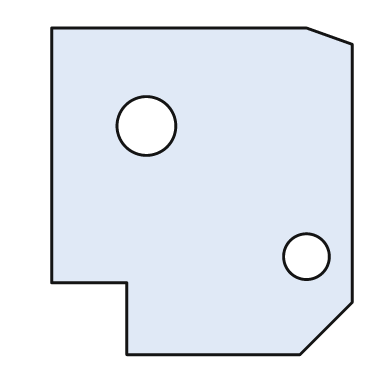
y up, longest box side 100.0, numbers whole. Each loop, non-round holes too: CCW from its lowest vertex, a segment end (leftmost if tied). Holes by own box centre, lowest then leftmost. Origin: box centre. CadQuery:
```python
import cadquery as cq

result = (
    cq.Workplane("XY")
    .moveTo(-23.0, -50.0)
    .lineTo(30.0, -50.0)
    .lineTo(46.0, -34.0)
    .lineTo(46.0, 45.0)
    .lineTo(32.0, 50.0)
    .lineTo(-46.0, 50.0)
    .lineTo(-46.0, -28.0)
    .lineTo(-23.0, -28.0)
    .close()
    .moveTo(32.0, -20.0)
    .circle(7.0)
    .moveTo(-17.0, 20.0)
    .circle(9.0)
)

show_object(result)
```